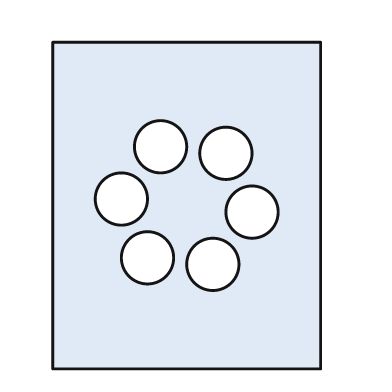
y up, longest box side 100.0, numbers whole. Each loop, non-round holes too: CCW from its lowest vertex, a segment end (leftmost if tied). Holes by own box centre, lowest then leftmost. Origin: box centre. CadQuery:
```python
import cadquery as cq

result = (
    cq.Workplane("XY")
    .moveTo(-41.0, -50.0)
    .lineTo(41.0, -50.0)
    .lineTo(41.0, 50.0)
    .lineTo(-41.0, 50.0)
    .close()
    .moveTo(8.0, -18.0)
    .circle(8.0)
    .moveTo(-12.0, -16.0)
    .circle(8.0)
    .moveTo(20.0, -2.0)
    .circle(8.0)
    .moveTo(-20.0, 2.0)
    .circle(8.0)
    .moveTo(12.0, 16.0)
    .circle(8.0)
    .moveTo(-8.0, 18.0)
    .circle(8.0)
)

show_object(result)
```